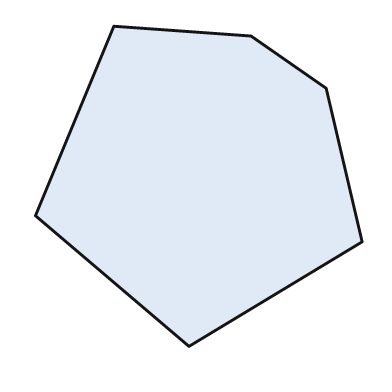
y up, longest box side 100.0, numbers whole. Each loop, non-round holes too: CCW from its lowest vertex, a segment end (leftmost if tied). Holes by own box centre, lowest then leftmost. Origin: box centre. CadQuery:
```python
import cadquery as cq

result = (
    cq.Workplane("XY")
    .moveTo(-3.0, -49.0)
    .lineTo(50.0, -17.0)
    .lineTo(39.0, 30.0)
    .lineTo(16.0, 46.0)
    .lineTo(-26.0, 49.0)
    .lineTo(-50.0, -9.0)
    .close()
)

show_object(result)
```